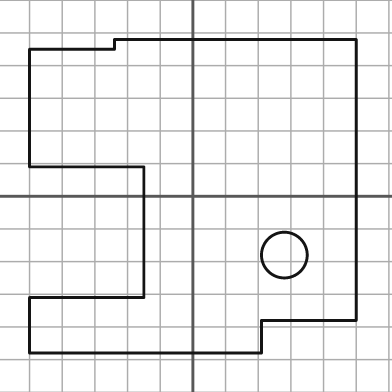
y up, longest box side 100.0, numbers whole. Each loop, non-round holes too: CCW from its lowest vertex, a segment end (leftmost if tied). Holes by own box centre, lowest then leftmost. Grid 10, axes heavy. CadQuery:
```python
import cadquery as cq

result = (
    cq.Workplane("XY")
    .moveTo(-50.0, -48.0)
    .lineTo(21.0, -48.0)
    .lineTo(21.0, -38.0)
    .lineTo(50.0, -38.0)
    .lineTo(50.0, 48.0)
    .lineTo(-24.0, 48.0)
    .lineTo(-24.0, 45.0)
    .lineTo(-50.0, 45.0)
    .lineTo(-50.0, 9.0)
    .lineTo(-15.0, 9.0)
    .lineTo(-15.0, -31.0)
    .lineTo(-50.0, -31.0)
    .close()
    .moveTo(28.0, -18.0)
    .circle(7.0)
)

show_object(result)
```